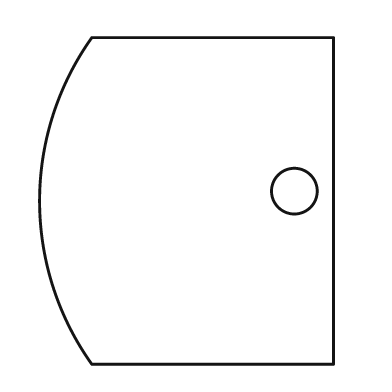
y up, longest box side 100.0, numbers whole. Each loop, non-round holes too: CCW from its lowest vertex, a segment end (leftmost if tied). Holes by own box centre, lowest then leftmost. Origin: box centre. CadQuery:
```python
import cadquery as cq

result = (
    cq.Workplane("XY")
    .moveTo(-29.0, -50.0)
    .lineTo(45.0, -50.0)
    .lineTo(45.0, 50.0)
    .lineTo(-29.0, 50.0)
    .threePointArc((-45.0, 0.0), (-29.0, -50.0))
    .close()
    .moveTo(33.0, 3.0)
    .circle(7.0)
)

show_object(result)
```